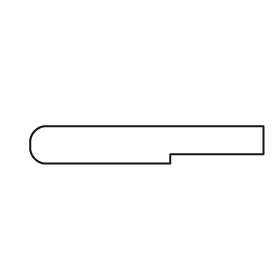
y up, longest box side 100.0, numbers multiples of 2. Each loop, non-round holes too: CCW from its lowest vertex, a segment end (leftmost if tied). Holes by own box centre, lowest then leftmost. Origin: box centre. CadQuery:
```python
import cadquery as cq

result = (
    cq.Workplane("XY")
    .moveTo(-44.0, -8.0)
    .lineTo(10.0, -8.0)
    .lineTo(10.0, -4.0)
    .lineTo(50.0, -4.0)
    .lineTo(50.0, 8.0)
    .lineTo(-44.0, 8.0)
    .threePointArc((-48.0, 6.0), (-50.0, 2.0))
    .lineTo(-50.0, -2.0)
    .threePointArc((-48.0, -6.0), (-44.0, -8.0))
    .close()
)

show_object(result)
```